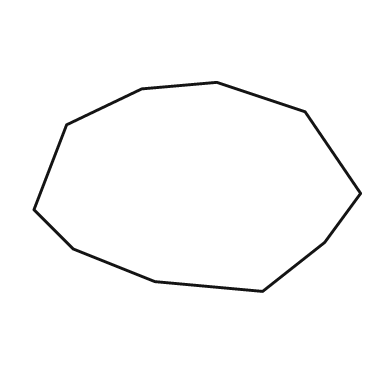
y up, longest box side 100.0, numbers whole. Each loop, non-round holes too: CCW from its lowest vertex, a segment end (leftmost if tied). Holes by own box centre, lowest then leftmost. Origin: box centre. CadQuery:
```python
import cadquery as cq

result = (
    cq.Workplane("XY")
    .moveTo(20.0, -32.0)
    .lineTo(39.0, -17.0)
    .lineTo(50.0, -2.0)
    .lineTo(33.0, 23.0)
    .lineTo(6.0, 32.0)
    .lineTo(-17.0, 30.0)
    .lineTo(-40.0, 19.0)
    .lineTo(-50.0, -7.0)
    .lineTo(-38.0, -19.0)
    .lineTo(-13.0, -29.0)
    .close()
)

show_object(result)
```